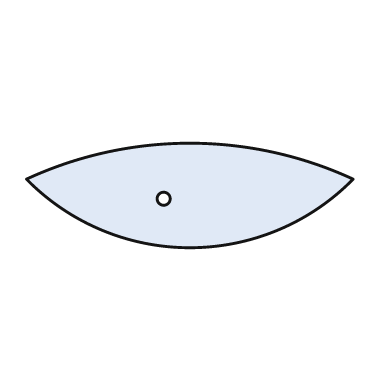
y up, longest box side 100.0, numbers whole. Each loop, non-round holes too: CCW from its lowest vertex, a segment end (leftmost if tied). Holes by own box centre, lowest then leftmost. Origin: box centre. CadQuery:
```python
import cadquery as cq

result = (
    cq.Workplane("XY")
    .moveTo(-50.0, 5.0)
    .threePointArc((0.0, -16.0), (50.0, 5.0))
    .threePointArc((0.0, 16.0), (-50.0, 5.0))
    .close()
    .moveTo(-8.0, -1.0)
    .circle(2.0)
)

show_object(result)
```